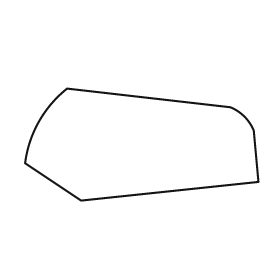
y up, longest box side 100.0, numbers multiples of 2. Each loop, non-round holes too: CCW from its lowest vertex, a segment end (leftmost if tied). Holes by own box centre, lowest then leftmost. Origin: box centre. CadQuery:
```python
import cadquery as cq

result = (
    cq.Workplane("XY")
    .moveTo(-26.0, -24.0)
    .lineTo(50.0, -16.0)
    .lineTo(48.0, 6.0)
    .threePointArc((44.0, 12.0), (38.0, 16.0))
    .lineTo(-32.0, 24.0)
    .threePointArc((-44.0, 10.0), (-50.0, -8.0))
    .close()
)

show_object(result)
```